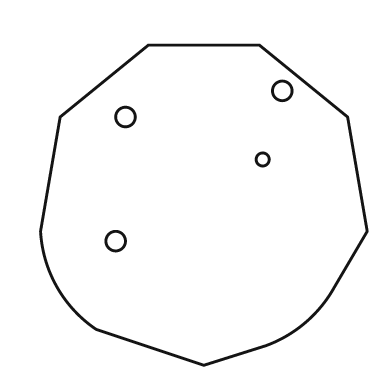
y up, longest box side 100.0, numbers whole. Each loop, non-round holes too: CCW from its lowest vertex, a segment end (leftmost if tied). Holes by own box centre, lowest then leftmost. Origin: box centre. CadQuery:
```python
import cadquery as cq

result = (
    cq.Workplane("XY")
    .moveTo(0.0, -49.0)
    .lineTo(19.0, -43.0)
    .threePointArc((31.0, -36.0), (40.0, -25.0))
    .lineTo(50.0, -8.0)
    .lineTo(44.0, 27.0)
    .lineTo(17.0, 49.0)
    .lineTo(-17.0, 49.0)
    .lineTo(-44.0, 27.0)
    .lineTo(-50.0, -8.0)
    .threePointArc((-45.0, -25.0), (-33.0, -38.0))
    .close()
    .moveTo(-27.0, -11.0)
    .circle(3.0)
    .moveTo(18.0, 14.0)
    .circle(2.0)
    .moveTo(-24.0, 27.0)
    .circle(3.0)
    .moveTo(24.0, 35.0)
    .circle(3.0)
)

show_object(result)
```